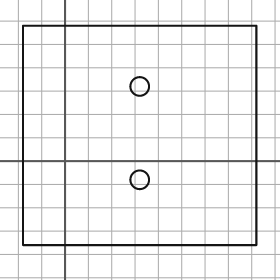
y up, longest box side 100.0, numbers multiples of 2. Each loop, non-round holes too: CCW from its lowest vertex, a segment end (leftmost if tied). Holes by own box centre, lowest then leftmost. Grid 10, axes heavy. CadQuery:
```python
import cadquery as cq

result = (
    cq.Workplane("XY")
    .moveTo(-18.0, -36.0)
    .lineTo(82.0, -36.0)
    .lineTo(82.0, 58.0)
    .lineTo(-18.0, 58.0)
    .close()
    .moveTo(32.0, -8.0)
    .circle(4.0)
    .moveTo(32.0, 32.0)
    .circle(4.0)
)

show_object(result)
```